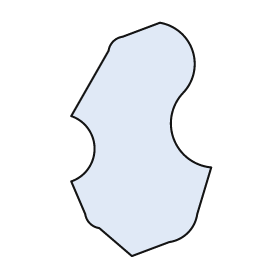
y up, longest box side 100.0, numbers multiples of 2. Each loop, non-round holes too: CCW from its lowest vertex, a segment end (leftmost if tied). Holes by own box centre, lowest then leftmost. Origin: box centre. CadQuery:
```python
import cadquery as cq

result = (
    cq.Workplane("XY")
    .moveTo(-4.0, -50.0)
    .lineTo(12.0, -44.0)
    .threePointArc((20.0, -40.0), (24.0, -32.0))
    .lineTo(30.0, -12.0)
    .threePointArc((14.0, 0.0), (18.0, 20.0))
    .threePointArc((22.0, 38.0), (8.0, 50.0))
    .lineTo(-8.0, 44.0)
    .threePointArc((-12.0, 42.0), (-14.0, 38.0))
    .lineTo(-30.0, 10.0)
    .threePointArc((-20.0, -4.0), (-30.0, -18.0))
    .lineTo(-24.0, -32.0)
    .threePointArc((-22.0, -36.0), (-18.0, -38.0))
    .close()
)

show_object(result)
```